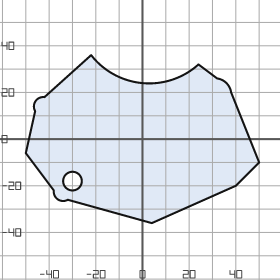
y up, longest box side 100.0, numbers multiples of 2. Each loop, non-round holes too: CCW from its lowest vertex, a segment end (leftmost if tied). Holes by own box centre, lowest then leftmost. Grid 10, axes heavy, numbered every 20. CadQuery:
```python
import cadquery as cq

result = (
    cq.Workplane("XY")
    .moveTo(4.0, -36.0)
    .lineTo(40.0, -20.0)
    .lineTo(50.0, -10.0)
    .lineTo(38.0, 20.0)
    .threePointArc((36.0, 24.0), (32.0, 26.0))
    .lineTo(24.0, 32.0)
    .threePointArc((0.0, 24.0), (-22.0, 36.0))
    .lineTo(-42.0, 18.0)
    .threePointArc((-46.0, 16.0), (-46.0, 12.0))
    .lineTo(-50.0, -6.0)
    .lineTo(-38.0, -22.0)
    .threePointArc((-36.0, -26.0), (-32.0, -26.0))
    .close()
    .moveTo(-30.0, -18.0)
    .circle(4.0)
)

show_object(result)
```